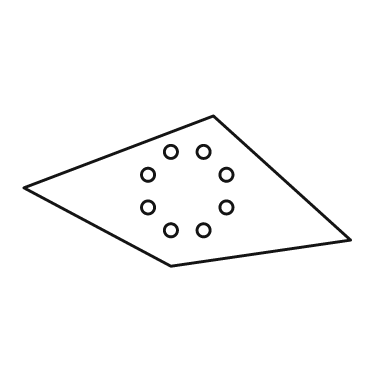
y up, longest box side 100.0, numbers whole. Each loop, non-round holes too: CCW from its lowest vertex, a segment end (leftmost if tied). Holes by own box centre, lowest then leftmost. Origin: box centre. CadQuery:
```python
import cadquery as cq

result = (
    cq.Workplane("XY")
    .moveTo(-5.0, -23.0)
    .lineTo(50.0, -15.0)
    .lineTo(8.0, 23.0)
    .lineTo(-50.0, 1.0)
    .close()
    .moveTo(-5.0, -12.0)
    .circle(2.0)
    .moveTo(5.0, -12.0)
    .circle(2.0)
    .moveTo(-12.0, -5.0)
    .circle(2.0)
    .moveTo(12.0, -5.0)
    .circle(2.0)
    .moveTo(-12.0, 5.0)
    .circle(2.0)
    .moveTo(12.0, 5.0)
    .circle(2.0)
    .moveTo(-5.0, 12.0)
    .circle(2.0)
    .moveTo(5.0, 12.0)
    .circle(2.0)
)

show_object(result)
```